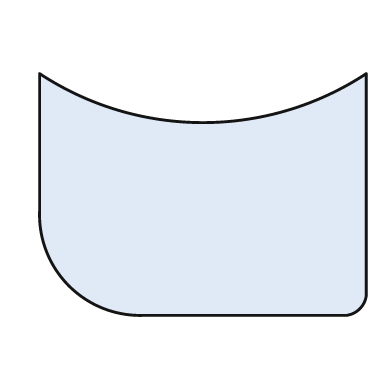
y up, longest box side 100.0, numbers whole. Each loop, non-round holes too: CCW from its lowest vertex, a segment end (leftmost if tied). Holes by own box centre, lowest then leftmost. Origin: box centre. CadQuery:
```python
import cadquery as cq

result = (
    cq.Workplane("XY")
    .moveTo(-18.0, -37.0)
    .lineTo(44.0, -37.0)
    .threePointArc((48.0, -35.0), (50.0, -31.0))
    .lineTo(50.0, 37.0)
    .threePointArc((0.0, 22.0), (-50.0, 37.0))
    .lineTo(-50.0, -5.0)
    .threePointArc((-41.0, -28.0), (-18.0, -37.0))
    .close()
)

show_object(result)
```